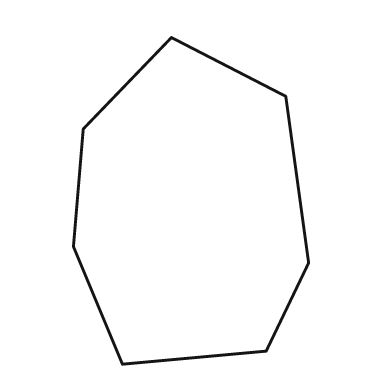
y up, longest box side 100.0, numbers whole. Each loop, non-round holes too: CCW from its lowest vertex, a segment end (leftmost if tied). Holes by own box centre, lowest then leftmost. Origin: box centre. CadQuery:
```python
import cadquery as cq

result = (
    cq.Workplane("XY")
    .moveTo(-21.0, -50.0)
    .lineTo(23.0, -46.0)
    .lineTo(36.0, -19.0)
    .lineTo(29.0, 32.0)
    .lineTo(-6.0, 50.0)
    .lineTo(-33.0, 22.0)
    .lineTo(-36.0, -14.0)
    .close()
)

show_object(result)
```